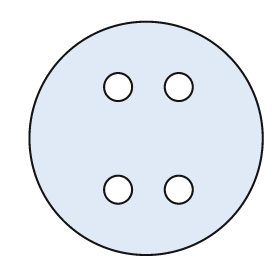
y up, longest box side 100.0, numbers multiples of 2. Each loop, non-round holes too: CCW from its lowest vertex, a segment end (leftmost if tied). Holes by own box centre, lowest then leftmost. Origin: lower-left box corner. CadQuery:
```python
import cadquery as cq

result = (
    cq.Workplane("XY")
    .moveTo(50.0, 50.0)
    .circle(50.0)
    .moveTo(38.0, 28.0)
    .circle(6.0)
    .moveTo(64.0, 28.0)
    .circle(6.0)
    .moveTo(38.0, 72.0)
    .circle(6.0)
    .moveTo(64.0, 72.0)
    .circle(6.0)
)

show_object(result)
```